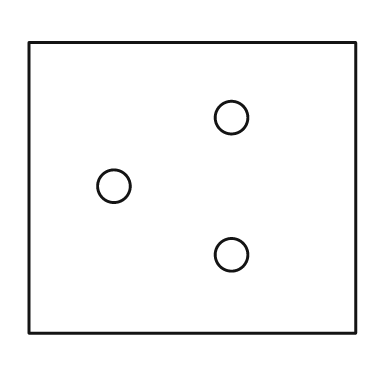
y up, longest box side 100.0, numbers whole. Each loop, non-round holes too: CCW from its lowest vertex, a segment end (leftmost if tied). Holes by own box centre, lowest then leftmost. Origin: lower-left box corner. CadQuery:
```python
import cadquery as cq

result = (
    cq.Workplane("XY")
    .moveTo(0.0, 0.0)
    .lineTo(100.0, 0.0)
    .lineTo(100.0, 89.0)
    .lineTo(0.0, 89.0)
    .close()
    .moveTo(62.0, 24.0)
    .circle(5.0)
    .moveTo(26.0, 45.0)
    .circle(5.0)
    .moveTo(62.0, 66.0)
    .circle(5.0)
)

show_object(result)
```